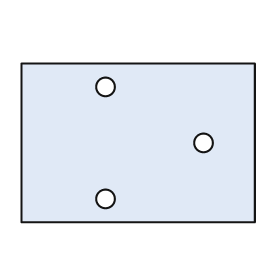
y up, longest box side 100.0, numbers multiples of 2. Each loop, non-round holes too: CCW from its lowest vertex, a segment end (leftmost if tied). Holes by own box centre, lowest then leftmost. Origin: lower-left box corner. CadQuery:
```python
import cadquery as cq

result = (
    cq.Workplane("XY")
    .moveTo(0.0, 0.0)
    .lineTo(100.0, 0.0)
    .lineTo(100.0, 68.0)
    .lineTo(0.0, 68.0)
    .close()
    .moveTo(36.0, 10.0)
    .circle(4.0)
    .moveTo(78.0, 34.0)
    .circle(4.0)
    .moveTo(36.0, 58.0)
    .circle(4.0)
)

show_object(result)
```